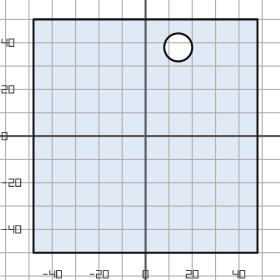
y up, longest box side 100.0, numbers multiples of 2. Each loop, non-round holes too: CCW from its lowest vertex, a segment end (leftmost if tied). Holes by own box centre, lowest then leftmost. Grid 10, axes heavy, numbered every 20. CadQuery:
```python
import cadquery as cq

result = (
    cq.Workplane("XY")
    .moveTo(-48.0, -50.0)
    .lineTo(48.0, -50.0)
    .lineTo(48.0, 50.0)
    .lineTo(-48.0, 50.0)
    .close()
    .moveTo(14.0, 38.0)
    .circle(6.0)
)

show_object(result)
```